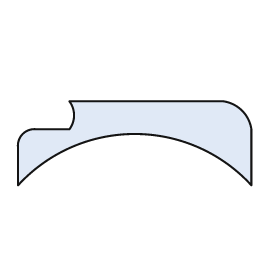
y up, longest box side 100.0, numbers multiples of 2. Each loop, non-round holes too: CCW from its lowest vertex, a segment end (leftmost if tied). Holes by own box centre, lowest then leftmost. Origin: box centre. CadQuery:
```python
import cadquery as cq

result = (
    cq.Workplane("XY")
    .moveTo(-50.0, -18.0)
    .threePointArc((0.0, 4.0), (50.0, -18.0))
    .lineTo(50.0, 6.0)
    .threePointArc((46.0, 14.0), (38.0, 18.0))
    .lineTo(-28.0, 18.0)
    .threePointArc((-26.0, 12.0), (-28.0, 6.0))
    .lineTo(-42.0, 6.0)
    .threePointArc((-48.0, 4.0), (-50.0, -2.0))
    .close()
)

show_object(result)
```